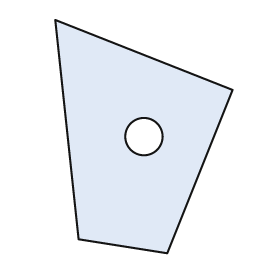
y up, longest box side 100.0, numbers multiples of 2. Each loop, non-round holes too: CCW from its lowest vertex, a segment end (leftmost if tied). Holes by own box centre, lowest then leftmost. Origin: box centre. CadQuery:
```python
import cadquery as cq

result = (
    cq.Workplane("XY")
    .moveTo(10.0, -50.0)
    .lineTo(38.0, 20.0)
    .lineTo(-38.0, 50.0)
    .lineTo(-28.0, -44.0)
    .close()
    .moveTo(0.0, 0.0)
    .circle(8.0)
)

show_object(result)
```